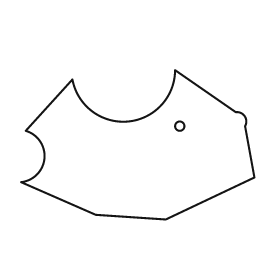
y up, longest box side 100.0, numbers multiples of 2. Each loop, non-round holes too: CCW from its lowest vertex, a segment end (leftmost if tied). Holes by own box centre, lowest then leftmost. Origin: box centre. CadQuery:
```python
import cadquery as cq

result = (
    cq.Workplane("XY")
    .moveTo(12.0, -32.0)
    .lineTo(50.0, -14.0)
    .lineTo(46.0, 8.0)
    .threePointArc((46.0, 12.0), (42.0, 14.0))
    .lineTo(16.0, 32.0)
    .threePointArc((-4.0, 10.0), (-28.0, 28.0))
    .lineTo(-48.0, 6.0)
    .threePointArc((-40.0, -6.0), (-50.0, -16.0))
    .lineTo(-18.0, -30.0)
    .close()
    .moveTo(18.0, 8.0)
    .circle(2.0)
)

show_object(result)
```